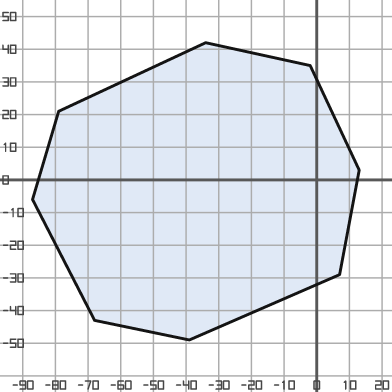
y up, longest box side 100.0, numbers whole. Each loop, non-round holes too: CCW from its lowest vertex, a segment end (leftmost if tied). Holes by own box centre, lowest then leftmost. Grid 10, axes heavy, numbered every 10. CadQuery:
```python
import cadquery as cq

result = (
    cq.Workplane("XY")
    .moveTo(-39.0, -49.0)
    .lineTo(7.0, -29.0)
    .lineTo(13.0, 3.0)
    .lineTo(-2.0, 35.0)
    .lineTo(-34.0, 42.0)
    .lineTo(-79.0, 21.0)
    .lineTo(-87.0, -6.0)
    .lineTo(-68.0, -43.0)
    .close()
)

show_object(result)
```